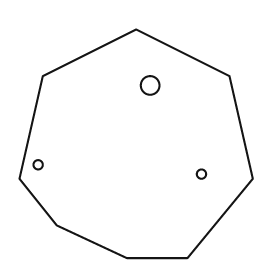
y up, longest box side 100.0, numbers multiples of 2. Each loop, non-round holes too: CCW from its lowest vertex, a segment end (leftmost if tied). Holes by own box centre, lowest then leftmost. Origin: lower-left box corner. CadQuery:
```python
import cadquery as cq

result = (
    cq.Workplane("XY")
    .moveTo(46.0, 0.0)
    .lineTo(72.0, 0.0)
    .lineTo(100.0, 34.0)
    .lineTo(90.0, 78.0)
    .lineTo(50.0, 98.0)
    .lineTo(10.0, 78.0)
    .lineTo(0.0, 34.0)
    .lineTo(16.0, 14.0)
    .close()
    .moveTo(78.0, 36.0)
    .circle(2.0)
    .moveTo(8.0, 40.0)
    .circle(2.0)
    .moveTo(56.0, 74.0)
    .circle(4.0)
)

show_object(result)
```